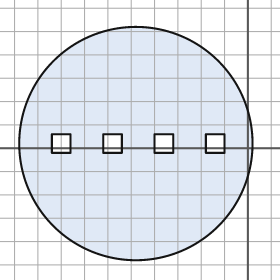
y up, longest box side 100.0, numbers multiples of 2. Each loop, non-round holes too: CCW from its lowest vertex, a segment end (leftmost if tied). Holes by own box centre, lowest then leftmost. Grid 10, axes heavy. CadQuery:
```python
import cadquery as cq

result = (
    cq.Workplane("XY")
    .moveTo(-48.0, 2.0)
    .circle(50.0)
    .moveTo(-84.0, -2.0)
    .lineTo(-76.0, -2.0)
    .lineTo(-76.0, 6.0)
    .lineTo(-84.0, 6.0)
    .close()
    .moveTo(-62.0, -2.0)
    .lineTo(-54.0, -2.0)
    .lineTo(-54.0, 6.0)
    .lineTo(-62.0, 6.0)
    .close()
    .moveTo(-40.0, -2.0)
    .lineTo(-32.0, -2.0)
    .lineTo(-32.0, 6.0)
    .lineTo(-40.0, 6.0)
    .close()
    .moveTo(-18.0, -2.0)
    .lineTo(-10.0, -2.0)
    .lineTo(-10.0, 6.0)
    .lineTo(-18.0, 6.0)
    .close()
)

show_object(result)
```